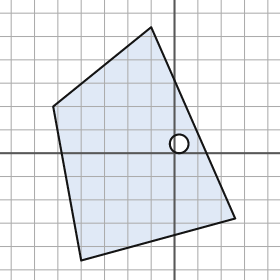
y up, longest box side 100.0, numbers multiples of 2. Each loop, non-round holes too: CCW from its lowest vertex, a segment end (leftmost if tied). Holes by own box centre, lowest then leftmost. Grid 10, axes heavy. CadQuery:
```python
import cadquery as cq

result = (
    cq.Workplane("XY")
    .moveTo(-40.0, -46.0)
    .lineTo(26.0, -28.0)
    .lineTo(-10.0, 54.0)
    .lineTo(-52.0, 20.0)
    .close()
    .moveTo(2.0, 4.0)
    .circle(4.0)
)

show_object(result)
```